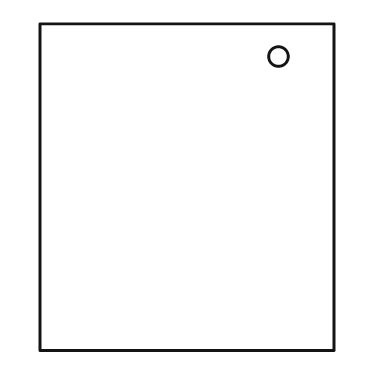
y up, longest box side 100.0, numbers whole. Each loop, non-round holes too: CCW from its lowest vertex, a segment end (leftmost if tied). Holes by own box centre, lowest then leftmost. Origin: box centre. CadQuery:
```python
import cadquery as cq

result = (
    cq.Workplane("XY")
    .moveTo(-45.0, -50.0)
    .lineTo(45.0, -50.0)
    .lineTo(45.0, 50.0)
    .lineTo(-45.0, 50.0)
    .close()
    .moveTo(28.0, 40.0)
    .circle(3.0)
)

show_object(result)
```